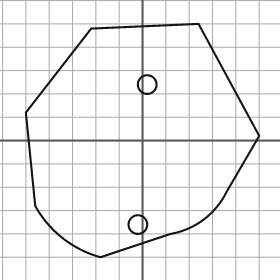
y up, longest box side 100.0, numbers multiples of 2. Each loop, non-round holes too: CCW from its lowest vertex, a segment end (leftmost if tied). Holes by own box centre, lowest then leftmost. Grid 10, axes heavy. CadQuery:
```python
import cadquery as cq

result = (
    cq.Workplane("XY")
    .moveTo(-18.0, -50.0)
    .lineTo(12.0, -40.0)
    .threePointArc((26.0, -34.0), (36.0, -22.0))
    .lineTo(50.0, 2.0)
    .lineTo(24.0, 50.0)
    .lineTo(-22.0, 48.0)
    .lineTo(-50.0, 12.0)
    .lineTo(-46.0, -28.0)
    .threePointArc((-34.0, -42.0), (-18.0, -50.0))
    .close()
    .moveTo(-2.0, -36.0)
    .circle(4.0)
    .moveTo(2.0, 24.0)
    .circle(4.0)
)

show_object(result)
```